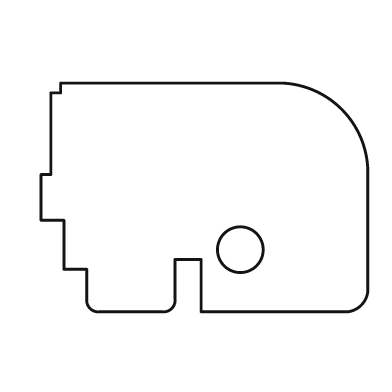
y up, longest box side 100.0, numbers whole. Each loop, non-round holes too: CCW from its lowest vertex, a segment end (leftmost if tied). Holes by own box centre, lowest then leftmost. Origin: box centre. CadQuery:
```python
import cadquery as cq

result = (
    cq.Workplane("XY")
    .moveTo(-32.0, -35.0)
    .lineTo(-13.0, -35.0)
    .threePointArc((-10.0, -34.0), (-9.0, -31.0))
    .lineTo(-9.0, -19.0)
    .lineTo(-1.0, -19.0)
    .lineTo(-1.0, -35.0)
    .lineTo(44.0, -35.0)
    .threePointArc((48.0, -33.0), (50.0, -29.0))
    .lineTo(50.0, 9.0)
    .threePointArc((42.0, 27.0), (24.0, 35.0))
    .lineTo(-44.0, 35.0)
    .lineTo(-44.0, 32.0)
    .lineTo(-47.0, 32.0)
    .lineTo(-47.0, 7.0)
    .lineTo(-50.0, 7.0)
    .lineTo(-50.0, -7.0)
    .lineTo(-43.0, -7.0)
    .lineTo(-43.0, -22.0)
    .lineTo(-36.0, -22.0)
    .lineTo(-36.0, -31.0)
    .threePointArc((-35.0, -34.0), (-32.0, -35.0))
    .close()
    .moveTo(11.0, -16.0)
    .circle(7.0)
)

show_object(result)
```